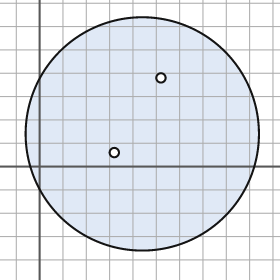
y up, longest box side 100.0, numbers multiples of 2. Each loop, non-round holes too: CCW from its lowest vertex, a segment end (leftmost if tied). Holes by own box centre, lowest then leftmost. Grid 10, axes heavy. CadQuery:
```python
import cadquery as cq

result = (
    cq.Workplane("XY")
    .moveTo(44.0, 14.0)
    .circle(50.0)
    .moveTo(32.0, 6.0)
    .circle(2.0)
    .moveTo(52.0, 38.0)
    .circle(2.0)
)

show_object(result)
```